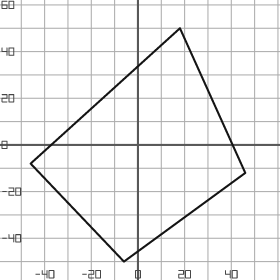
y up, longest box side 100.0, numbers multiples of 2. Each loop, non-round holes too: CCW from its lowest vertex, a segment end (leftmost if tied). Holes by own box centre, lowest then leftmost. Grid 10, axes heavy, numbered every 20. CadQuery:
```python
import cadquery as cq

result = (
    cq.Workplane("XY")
    .moveTo(-6.0, -50.0)
    .lineTo(46.0, -12.0)
    .lineTo(18.0, 50.0)
    .lineTo(-46.0, -8.0)
    .close()
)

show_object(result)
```